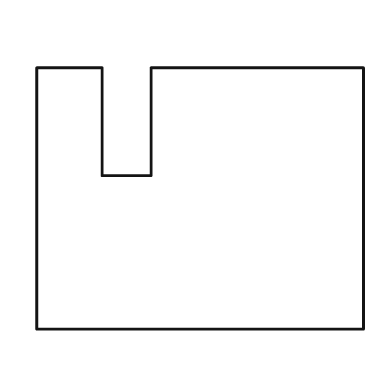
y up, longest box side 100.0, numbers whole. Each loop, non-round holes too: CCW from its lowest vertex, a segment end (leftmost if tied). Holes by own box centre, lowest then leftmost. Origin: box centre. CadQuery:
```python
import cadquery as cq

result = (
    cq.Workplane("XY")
    .moveTo(-50.0, -40.0)
    .lineTo(50.0, -40.0)
    .lineTo(50.0, 40.0)
    .lineTo(-15.0, 40.0)
    .lineTo(-15.0, 7.0)
    .lineTo(-30.0, 7.0)
    .lineTo(-30.0, 40.0)
    .lineTo(-50.0, 40.0)
    .close()
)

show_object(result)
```